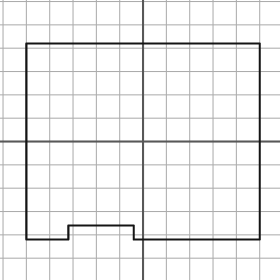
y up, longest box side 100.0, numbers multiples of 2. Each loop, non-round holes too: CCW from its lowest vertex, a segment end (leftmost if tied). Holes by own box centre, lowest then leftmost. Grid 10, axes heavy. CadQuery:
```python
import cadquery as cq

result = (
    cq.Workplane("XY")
    .moveTo(-50.0, -42.0)
    .lineTo(-32.0, -42.0)
    .lineTo(-32.0, -36.0)
    .lineTo(-4.0, -36.0)
    .lineTo(-4.0, -42.0)
    .lineTo(50.0, -42.0)
    .lineTo(50.0, 42.0)
    .lineTo(-50.0, 42.0)
    .close()
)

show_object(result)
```